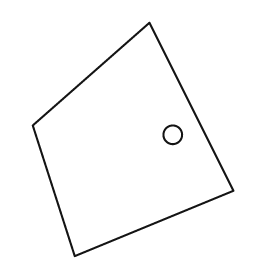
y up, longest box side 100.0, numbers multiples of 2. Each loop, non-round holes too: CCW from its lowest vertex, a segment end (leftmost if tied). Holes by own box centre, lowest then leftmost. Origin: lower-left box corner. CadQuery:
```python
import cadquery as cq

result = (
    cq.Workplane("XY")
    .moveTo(18.0, 0.0)
    .lineTo(86.0, 28.0)
    .lineTo(50.0, 100.0)
    .lineTo(0.0, 56.0)
    .close()
    .moveTo(60.0, 52.0)
    .circle(4.0)
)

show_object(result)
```